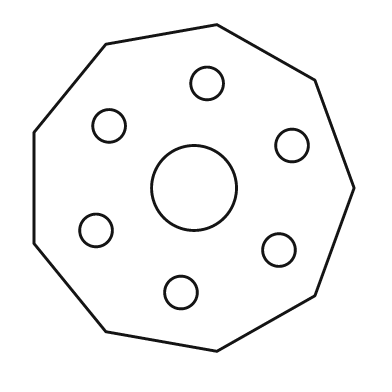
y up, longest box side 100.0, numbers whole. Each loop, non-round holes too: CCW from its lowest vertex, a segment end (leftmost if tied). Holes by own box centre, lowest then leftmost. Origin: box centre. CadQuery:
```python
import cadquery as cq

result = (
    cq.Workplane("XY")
    .moveTo(7.0, -50.0)
    .lineTo(37.0, -33.0)
    .lineTo(49.0, 0.0)
    .lineTo(37.0, 33.0)
    .lineTo(7.0, 50.0)
    .lineTo(-27.0, 44.0)
    .lineTo(-49.0, 17.0)
    .lineTo(-49.0, -17.0)
    .lineTo(-27.0, -44.0)
    .close()
    .moveTo(-4.0, -32.0)
    .circle(5.0)
    .moveTo(26.0, -19.0)
    .circle(5.0)
    .moveTo(-30.0, -13.0)
    .circle(5.0)
    .moveTo(0.0, 0.0)
    .circle(13.0)
    .moveTo(30.0, 13.0)
    .circle(5.0)
    .moveTo(-26.0, 19.0)
    .circle(5.0)
    .moveTo(4.0, 32.0)
    .circle(5.0)
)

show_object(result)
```